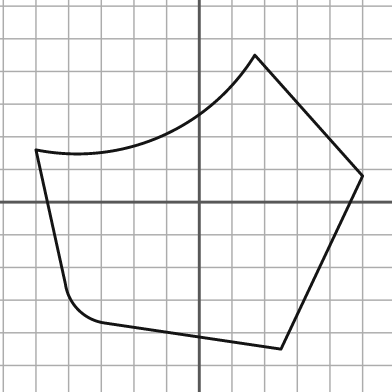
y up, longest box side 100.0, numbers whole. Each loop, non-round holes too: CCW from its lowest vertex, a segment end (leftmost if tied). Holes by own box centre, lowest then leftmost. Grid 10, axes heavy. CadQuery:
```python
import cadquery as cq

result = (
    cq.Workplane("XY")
    .moveTo(25.0, -45.0)
    .lineTo(50.0, 8.0)
    .lineTo(17.0, 45.0)
    .threePointArc((-12.0, 20.0), (-50.0, 16.0))
    .lineTo(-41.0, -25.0)
    .threePointArc((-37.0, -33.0), (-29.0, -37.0))
    .close()
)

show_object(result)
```